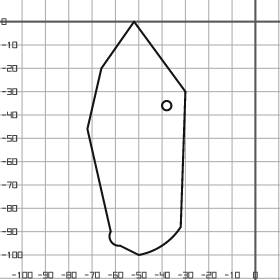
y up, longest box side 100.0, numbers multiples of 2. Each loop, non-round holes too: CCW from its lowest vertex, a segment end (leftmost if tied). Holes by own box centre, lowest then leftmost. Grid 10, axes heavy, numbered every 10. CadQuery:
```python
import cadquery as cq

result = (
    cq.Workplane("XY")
    .moveTo(-50.0, -100.0)
    .threePointArc((-40.0, -96.0), (-32.0, -88.0))
    .lineTo(-30.0, -30.0)
    .lineTo(-52.0, 0.0)
    .lineTo(-66.0, -20.0)
    .lineTo(-72.0, -46.0)
    .lineTo(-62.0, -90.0)
    .threePointArc((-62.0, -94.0), (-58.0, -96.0))
    .close()
    .moveTo(-38.0, -36.0)
    .circle(2.0)
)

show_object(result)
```